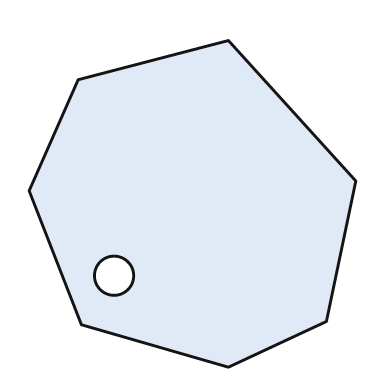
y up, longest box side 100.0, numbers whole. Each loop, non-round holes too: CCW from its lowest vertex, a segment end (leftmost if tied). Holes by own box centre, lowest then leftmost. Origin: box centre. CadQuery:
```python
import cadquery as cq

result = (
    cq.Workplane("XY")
    .moveTo(11.0, -50.0)
    .lineTo(41.0, -36.0)
    .lineTo(50.0, 7.0)
    .lineTo(11.0, 50.0)
    .lineTo(-35.0, 38.0)
    .lineTo(-50.0, 4.0)
    .lineTo(-34.0, -37.0)
    .close()
    .moveTo(-24.0, -22.0)
    .circle(6.0)
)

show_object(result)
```